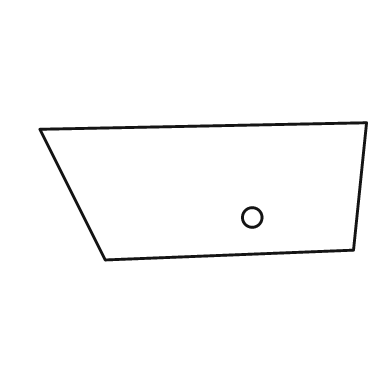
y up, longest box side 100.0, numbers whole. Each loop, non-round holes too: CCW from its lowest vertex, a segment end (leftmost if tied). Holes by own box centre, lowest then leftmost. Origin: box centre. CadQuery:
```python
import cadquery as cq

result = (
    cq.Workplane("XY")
    .moveTo(-30.0, -21.0)
    .lineTo(46.0, -18.0)
    .lineTo(50.0, 21.0)
    .lineTo(-50.0, 19.0)
    .close()
    .moveTo(15.0, -8.0)
    .circle(3.0)
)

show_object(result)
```